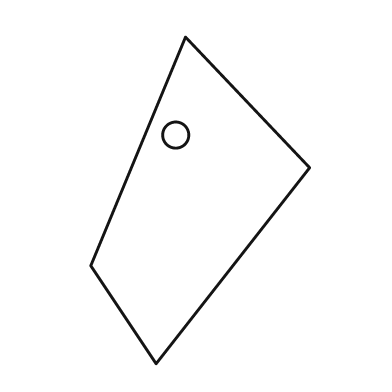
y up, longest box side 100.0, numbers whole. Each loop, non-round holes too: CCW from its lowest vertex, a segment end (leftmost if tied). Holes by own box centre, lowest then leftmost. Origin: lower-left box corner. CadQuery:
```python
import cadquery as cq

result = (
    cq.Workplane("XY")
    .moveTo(20.0, 0.0)
    .lineTo(67.0, 60.0)
    .lineTo(29.0, 100.0)
    .lineTo(0.0, 30.0)
    .close()
    .moveTo(26.0, 70.0)
    .circle(4.0)
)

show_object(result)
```